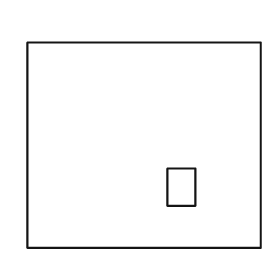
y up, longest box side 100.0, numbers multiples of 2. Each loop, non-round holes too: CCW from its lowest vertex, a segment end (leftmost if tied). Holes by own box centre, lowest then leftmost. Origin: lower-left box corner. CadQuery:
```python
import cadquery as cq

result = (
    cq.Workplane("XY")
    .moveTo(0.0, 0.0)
    .lineTo(100.0, 0.0)
    .lineTo(100.0, 88.0)
    .lineTo(0.0, 88.0)
    .close()
    .moveTo(60.0, 18.0)
    .lineTo(72.0, 18.0)
    .lineTo(72.0, 34.0)
    .lineTo(60.0, 34.0)
    .close()
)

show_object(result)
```